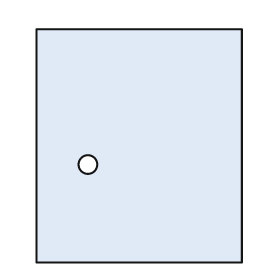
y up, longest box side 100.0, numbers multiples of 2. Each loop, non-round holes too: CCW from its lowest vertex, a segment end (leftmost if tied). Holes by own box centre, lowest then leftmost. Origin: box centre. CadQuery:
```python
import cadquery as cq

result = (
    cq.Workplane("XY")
    .moveTo(-44.0, -50.0)
    .lineTo(44.0, -50.0)
    .lineTo(44.0, 50.0)
    .lineTo(-44.0, 50.0)
    .close()
    .moveTo(-22.0, -8.0)
    .circle(4.0)
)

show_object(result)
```